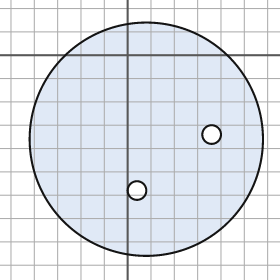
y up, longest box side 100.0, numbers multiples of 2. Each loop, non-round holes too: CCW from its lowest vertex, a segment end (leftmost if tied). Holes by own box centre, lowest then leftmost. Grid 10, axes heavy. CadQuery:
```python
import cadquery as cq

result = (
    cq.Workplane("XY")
    .moveTo(8.0, -36.0)
    .circle(50.0)
    .moveTo(4.0, -58.0)
    .circle(4.0)
    .moveTo(36.0, -34.0)
    .circle(4.0)
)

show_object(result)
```